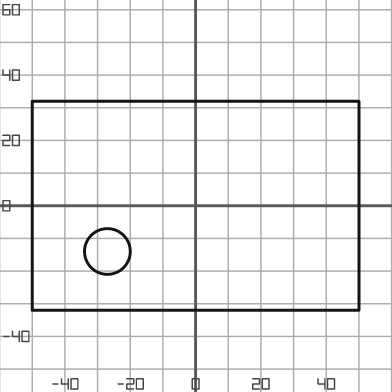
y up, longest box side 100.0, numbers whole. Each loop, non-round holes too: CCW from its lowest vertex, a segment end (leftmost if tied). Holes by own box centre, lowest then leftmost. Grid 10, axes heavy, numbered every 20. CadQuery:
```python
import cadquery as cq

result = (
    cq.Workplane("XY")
    .moveTo(-50.0, -32.0)
    .lineTo(50.0, -32.0)
    .lineTo(50.0, 32.0)
    .lineTo(-50.0, 32.0)
    .close()
    .moveTo(-27.0, -14.0)
    .circle(7.0)
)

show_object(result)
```